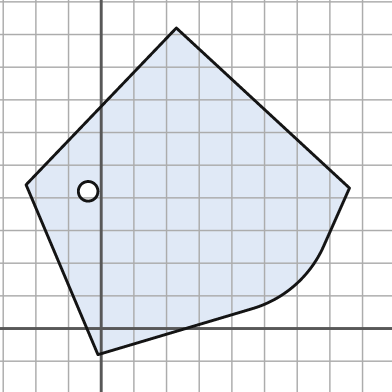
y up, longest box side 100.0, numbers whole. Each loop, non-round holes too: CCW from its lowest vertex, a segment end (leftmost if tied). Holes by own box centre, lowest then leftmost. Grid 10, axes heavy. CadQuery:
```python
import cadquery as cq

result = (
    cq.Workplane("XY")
    .moveTo(-1.0, -8.0)
    .lineTo(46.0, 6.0)
    .threePointArc((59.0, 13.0), (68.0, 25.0))
    .lineTo(76.0, 43.0)
    .lineTo(23.0, 92.0)
    .lineTo(-23.0, 44.0)
    .close()
    .moveTo(-4.0, 42.0)
    .circle(3.0)
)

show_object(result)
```